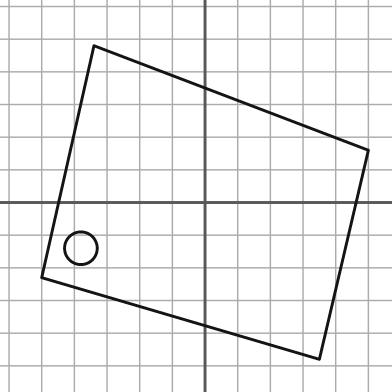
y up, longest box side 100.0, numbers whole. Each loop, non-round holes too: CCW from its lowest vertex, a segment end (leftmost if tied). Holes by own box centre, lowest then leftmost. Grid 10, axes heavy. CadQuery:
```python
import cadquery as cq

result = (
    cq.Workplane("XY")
    .moveTo(35.0, -48.0)
    .lineTo(50.0, 16.0)
    .lineTo(-34.0, 48.0)
    .lineTo(-50.0, -23.0)
    .close()
    .moveTo(-38.0, -14.0)
    .circle(5.0)
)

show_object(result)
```